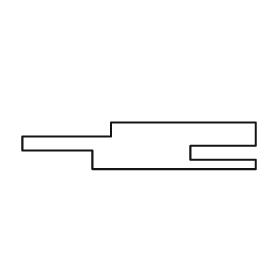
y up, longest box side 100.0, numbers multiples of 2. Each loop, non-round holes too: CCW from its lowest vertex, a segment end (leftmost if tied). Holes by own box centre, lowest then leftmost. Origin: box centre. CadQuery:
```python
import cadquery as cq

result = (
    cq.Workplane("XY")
    .moveTo(-20.0, -10.0)
    .lineTo(50.0, -10.0)
    .lineTo(50.0, -6.0)
    .lineTo(22.0, -6.0)
    .lineTo(22.0, 0.0)
    .lineTo(50.0, 0.0)
    .lineTo(50.0, 10.0)
    .lineTo(-12.0, 10.0)
    .lineTo(-12.0, 4.0)
    .lineTo(-50.0, 4.0)
    .lineTo(-50.0, -2.0)
    .lineTo(-20.0, -2.0)
    .close()
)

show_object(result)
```